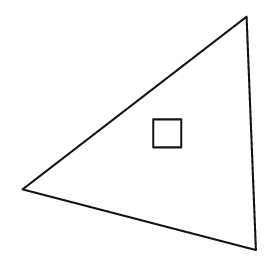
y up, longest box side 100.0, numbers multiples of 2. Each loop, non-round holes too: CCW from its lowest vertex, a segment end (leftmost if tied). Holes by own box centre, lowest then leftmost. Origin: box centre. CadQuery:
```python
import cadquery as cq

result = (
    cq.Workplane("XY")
    .moveTo(50.0, -50.0)
    .lineTo(46.0, 50.0)
    .lineTo(-50.0, -24.0)
    .close()
    .moveTo(6.0, -6.0)
    .lineTo(18.0, -6.0)
    .lineTo(18.0, 6.0)
    .lineTo(6.0, 6.0)
    .close()
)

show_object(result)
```